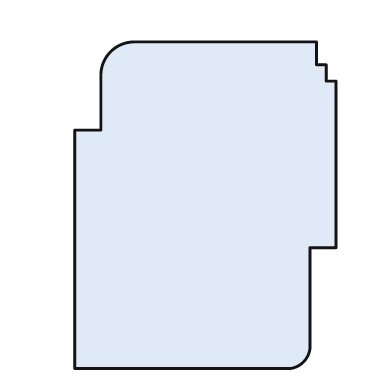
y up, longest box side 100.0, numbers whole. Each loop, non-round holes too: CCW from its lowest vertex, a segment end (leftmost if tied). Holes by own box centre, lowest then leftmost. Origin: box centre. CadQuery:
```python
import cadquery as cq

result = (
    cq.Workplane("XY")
    .moveTo(-40.0, -50.0)
    .lineTo(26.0, -50.0)
    .threePointArc((30.0, -48.0), (32.0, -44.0))
    .lineTo(32.0, -13.0)
    .lineTo(40.0, -13.0)
    .lineTo(40.0, 38.0)
    .lineTo(37.0, 38.0)
    .lineTo(37.0, 43.0)
    .lineTo(34.0, 43.0)
    .lineTo(34.0, 50.0)
    .lineTo(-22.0, 50.0)
    .threePointArc((-29.0, 47.0), (-32.0, 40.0))
    .lineTo(-32.0, 23.0)
    .lineTo(-40.0, 23.0)
    .close()
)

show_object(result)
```